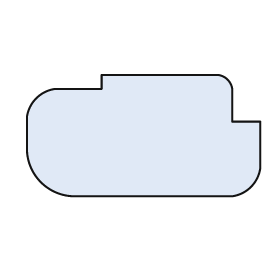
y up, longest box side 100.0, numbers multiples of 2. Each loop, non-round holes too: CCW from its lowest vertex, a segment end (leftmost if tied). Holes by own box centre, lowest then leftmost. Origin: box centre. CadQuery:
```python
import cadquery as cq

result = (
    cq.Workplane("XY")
    .moveTo(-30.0, -26.0)
    .lineTo(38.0, -26.0)
    .threePointArc((46.0, -22.0), (50.0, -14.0))
    .lineTo(50.0, 6.0)
    .lineTo(38.0, 6.0)
    .lineTo(38.0, 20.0)
    .threePointArc((36.0, 24.0), (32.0, 26.0))
    .lineTo(-18.0, 26.0)
    .lineTo(-18.0, 20.0)
    .lineTo(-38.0, 20.0)
    .threePointArc((-46.0, 16.0), (-50.0, 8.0))
    .lineTo(-50.0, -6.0)
    .threePointArc((-44.0, -20.0), (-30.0, -26.0))
    .close()
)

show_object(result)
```